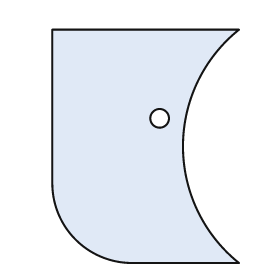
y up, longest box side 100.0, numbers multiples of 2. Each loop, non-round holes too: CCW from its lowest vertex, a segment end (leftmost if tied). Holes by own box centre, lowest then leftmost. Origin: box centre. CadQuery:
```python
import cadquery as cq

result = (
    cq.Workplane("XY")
    .moveTo(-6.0, -50.0)
    .lineTo(40.0, -50.0)
    .threePointArc((16.0, 0.0), (40.0, 50.0))
    .lineTo(-40.0, 50.0)
    .lineTo(-40.0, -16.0)
    .threePointArc((-30.0, -40.0), (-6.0, -50.0))
    .close()
    .moveTo(6.0, 12.0)
    .circle(4.0)
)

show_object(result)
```